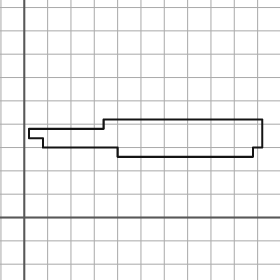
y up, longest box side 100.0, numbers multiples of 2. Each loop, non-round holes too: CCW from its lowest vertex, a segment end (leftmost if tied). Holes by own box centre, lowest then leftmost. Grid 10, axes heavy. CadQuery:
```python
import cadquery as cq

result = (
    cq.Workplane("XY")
    .moveTo(40.0, 26.0)
    .lineTo(98.0, 26.0)
    .lineTo(98.0, 30.0)
    .lineTo(102.0, 30.0)
    .lineTo(102.0, 42.0)
    .lineTo(34.0, 42.0)
    .lineTo(34.0, 38.0)
    .lineTo(2.0, 38.0)
    .lineTo(2.0, 34.0)
    .lineTo(8.0, 34.0)
    .lineTo(8.0, 30.0)
    .lineTo(40.0, 30.0)
    .close()
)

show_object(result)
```